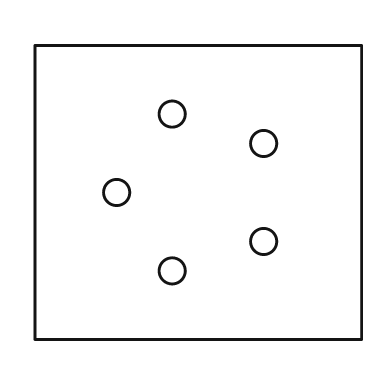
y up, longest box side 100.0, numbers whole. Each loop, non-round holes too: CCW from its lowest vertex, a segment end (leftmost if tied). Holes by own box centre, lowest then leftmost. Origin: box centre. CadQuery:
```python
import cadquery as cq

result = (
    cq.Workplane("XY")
    .moveTo(-50.0, -45.0)
    .lineTo(50.0, -45.0)
    .lineTo(50.0, 45.0)
    .lineTo(-50.0, 45.0)
    .close()
    .moveTo(-8.0, -24.0)
    .circle(4.0)
    .moveTo(20.0, -15.0)
    .circle(4.0)
    .moveTo(-25.0, 0.0)
    .circle(4.0)
    .moveTo(20.0, 15.0)
    .circle(4.0)
    .moveTo(-8.0, 24.0)
    .circle(4.0)
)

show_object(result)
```